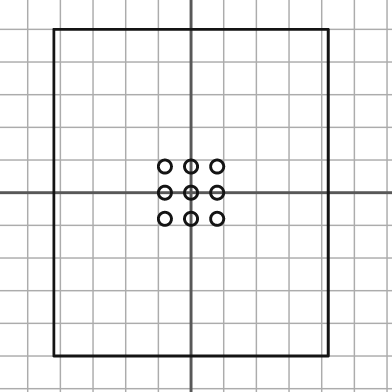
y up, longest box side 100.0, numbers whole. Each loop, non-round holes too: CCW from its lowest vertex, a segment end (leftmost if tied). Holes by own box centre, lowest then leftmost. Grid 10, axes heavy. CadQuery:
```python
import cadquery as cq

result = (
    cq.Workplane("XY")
    .moveTo(-42.0, -50.0)
    .lineTo(42.0, -50.0)
    .lineTo(42.0, 50.0)
    .lineTo(-42.0, 50.0)
    .close()
    .moveTo(-8.0, -8.0)
    .circle(2.0)
    .moveTo(0.0, -8.0)
    .circle(2.0)
    .moveTo(8.0, -8.0)
    .circle(2.0)
    .moveTo(-8.0, 0.0)
    .circle(2.0)
    .moveTo(0.0, 0.0)
    .circle(2.0)
    .moveTo(8.0, 0.0)
    .circle(2.0)
    .moveTo(-8.0, 8.0)
    .circle(2.0)
    .moveTo(0.0, 8.0)
    .circle(2.0)
    .moveTo(8.0, 8.0)
    .circle(2.0)
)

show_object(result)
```